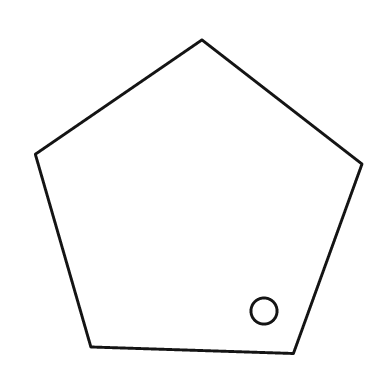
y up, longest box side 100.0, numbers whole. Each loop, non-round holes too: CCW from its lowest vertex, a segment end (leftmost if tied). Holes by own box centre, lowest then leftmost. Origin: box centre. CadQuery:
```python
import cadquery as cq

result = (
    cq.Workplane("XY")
    .moveTo(29.0, -48.0)
    .lineTo(50.0, 10.0)
    .lineTo(1.0, 48.0)
    .lineTo(-50.0, 13.0)
    .lineTo(-33.0, -46.0)
    .close()
    .moveTo(20.0, -35.0)
    .circle(4.0)
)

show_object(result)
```